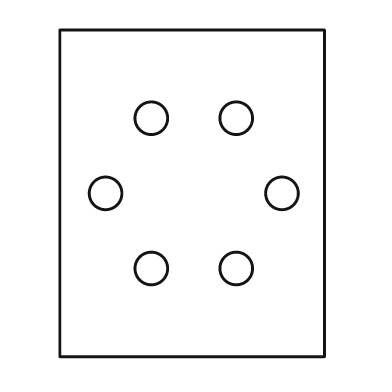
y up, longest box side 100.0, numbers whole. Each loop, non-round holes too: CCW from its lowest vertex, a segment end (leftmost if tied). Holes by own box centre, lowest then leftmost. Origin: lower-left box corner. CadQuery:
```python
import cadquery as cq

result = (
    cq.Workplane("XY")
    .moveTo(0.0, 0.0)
    .lineTo(81.0, 0.0)
    .lineTo(81.0, 100.0)
    .lineTo(0.0, 100.0)
    .close()
    .moveTo(28.0, 27.0)
    .circle(5.0)
    .moveTo(54.0, 27.0)
    .circle(5.0)
    .moveTo(14.0, 50.0)
    .circle(5.0)
    .moveTo(68.0, 50.0)
    .circle(5.0)
    .moveTo(28.0, 73.0)
    .circle(5.0)
    .moveTo(54.0, 73.0)
    .circle(5.0)
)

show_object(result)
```